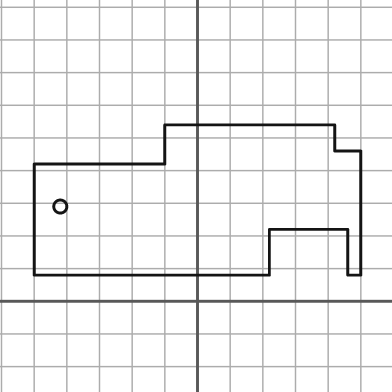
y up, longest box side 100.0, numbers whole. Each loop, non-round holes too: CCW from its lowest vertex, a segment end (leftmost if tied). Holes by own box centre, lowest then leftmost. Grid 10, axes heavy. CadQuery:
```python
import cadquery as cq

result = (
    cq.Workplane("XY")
    .moveTo(-50.0, 8.0)
    .lineTo(22.0, 8.0)
    .lineTo(22.0, 22.0)
    .lineTo(46.0, 22.0)
    .lineTo(46.0, 8.0)
    .lineTo(50.0, 8.0)
    .lineTo(50.0, 46.0)
    .lineTo(42.0, 46.0)
    .lineTo(42.0, 54.0)
    .lineTo(-10.0, 54.0)
    .lineTo(-10.0, 42.0)
    .lineTo(-50.0, 42.0)
    .close()
    .moveTo(-42.0, 29.0)
    .circle(2.0)
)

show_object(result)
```